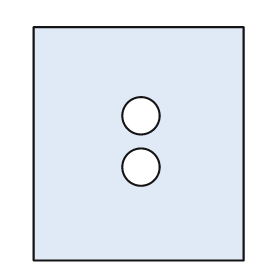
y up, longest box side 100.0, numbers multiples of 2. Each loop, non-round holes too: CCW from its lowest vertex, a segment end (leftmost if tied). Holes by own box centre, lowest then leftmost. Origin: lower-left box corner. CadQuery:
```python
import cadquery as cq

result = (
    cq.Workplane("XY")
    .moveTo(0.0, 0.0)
    .lineTo(90.0, 0.0)
    .lineTo(90.0, 100.0)
    .lineTo(0.0, 100.0)
    .close()
    .moveTo(46.0, 40.0)
    .circle(8.0)
    .moveTo(46.0, 62.0)
    .circle(8.0)
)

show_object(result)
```